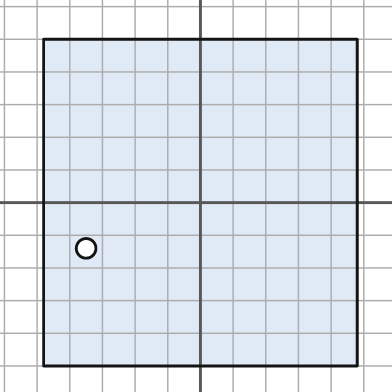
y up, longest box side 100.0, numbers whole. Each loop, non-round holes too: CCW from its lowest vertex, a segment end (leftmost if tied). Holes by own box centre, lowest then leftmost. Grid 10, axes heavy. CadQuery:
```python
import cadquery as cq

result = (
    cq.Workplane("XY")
    .moveTo(-48.0, -50.0)
    .lineTo(48.0, -50.0)
    .lineTo(48.0, 50.0)
    .lineTo(-48.0, 50.0)
    .close()
    .moveTo(-35.0, -14.0)
    .circle(3.0)
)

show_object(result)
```